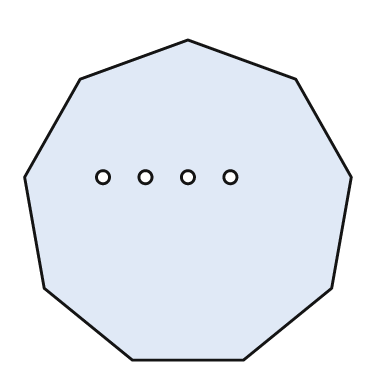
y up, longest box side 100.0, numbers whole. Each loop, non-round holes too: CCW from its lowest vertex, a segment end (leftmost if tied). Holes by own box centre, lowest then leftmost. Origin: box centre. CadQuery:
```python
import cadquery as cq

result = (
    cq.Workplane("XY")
    .moveTo(-17.0, -49.0)
    .lineTo(17.0, -49.0)
    .lineTo(44.0, -27.0)
    .lineTo(50.0, 7.0)
    .lineTo(33.0, 37.0)
    .lineTo(0.0, 49.0)
    .lineTo(-33.0, 37.0)
    .lineTo(-50.0, 7.0)
    .lineTo(-44.0, -27.0)
    .close()
    .moveTo(-26.0, 7.0)
    .circle(2.0)
    .moveTo(-13.0, 7.0)
    .circle(2.0)
    .moveTo(0.0, 7.0)
    .circle(2.0)
    .moveTo(13.0, 7.0)
    .circle(2.0)
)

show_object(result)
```